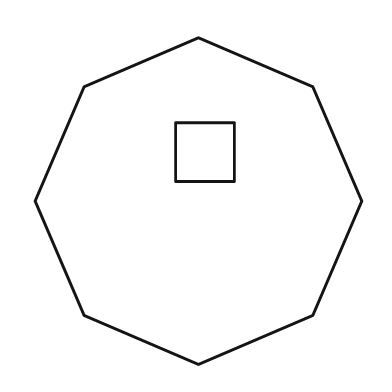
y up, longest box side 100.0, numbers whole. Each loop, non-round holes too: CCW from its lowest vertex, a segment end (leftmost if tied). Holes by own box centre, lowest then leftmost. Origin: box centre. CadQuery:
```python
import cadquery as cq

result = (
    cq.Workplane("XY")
    .moveTo(0.0, -50.0)
    .lineTo(35.0, -35.0)
    .lineTo(50.0, 0.0)
    .lineTo(35.0, 35.0)
    .lineTo(0.0, 50.0)
    .lineTo(-35.0, 35.0)
    .lineTo(-50.0, 0.0)
    .lineTo(-35.0, -35.0)
    .close()
    .moveTo(-7.0, 6.0)
    .lineTo(11.0, 6.0)
    .lineTo(11.0, 24.0)
    .lineTo(-7.0, 24.0)
    .close()
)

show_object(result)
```